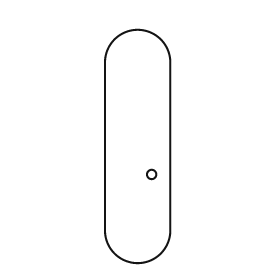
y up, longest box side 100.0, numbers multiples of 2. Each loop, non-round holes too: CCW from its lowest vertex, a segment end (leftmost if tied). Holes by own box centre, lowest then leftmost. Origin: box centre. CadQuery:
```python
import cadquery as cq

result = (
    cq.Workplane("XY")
    .moveTo(-14.0, -36.0)
    .threePointArc((0.0, -50.0), (14.0, -36.0))
    .lineTo(14.0, 36.0)
    .threePointArc((0.0, 50.0), (-14.0, 36.0))
    .close()
    .moveTo(6.0, -12.0)
    .circle(2.0)
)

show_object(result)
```